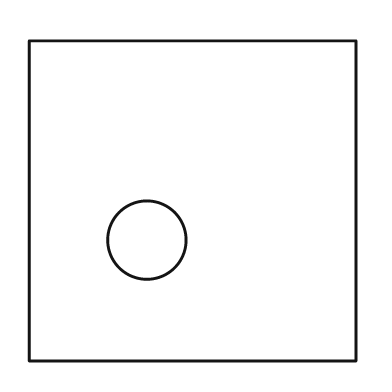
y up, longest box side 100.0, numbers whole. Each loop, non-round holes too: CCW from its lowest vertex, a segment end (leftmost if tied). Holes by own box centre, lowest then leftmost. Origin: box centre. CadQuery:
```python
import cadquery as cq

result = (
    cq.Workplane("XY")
    .moveTo(-50.0, -49.0)
    .lineTo(50.0, -49.0)
    .lineTo(50.0, 49.0)
    .lineTo(-50.0, 49.0)
    .close()
    .moveTo(-14.0, -12.0)
    .circle(12.0)
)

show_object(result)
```